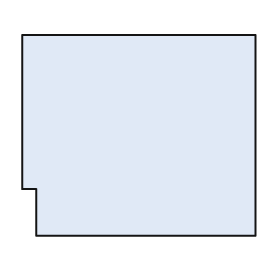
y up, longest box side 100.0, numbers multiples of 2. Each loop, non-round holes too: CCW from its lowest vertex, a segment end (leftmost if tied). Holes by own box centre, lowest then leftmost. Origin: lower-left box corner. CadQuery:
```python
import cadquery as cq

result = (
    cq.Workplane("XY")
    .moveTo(6.0, 0.0)
    .lineTo(100.0, 0.0)
    .lineTo(100.0, 86.0)
    .lineTo(0.0, 86.0)
    .lineTo(0.0, 20.0)
    .lineTo(6.0, 20.0)
    .close()
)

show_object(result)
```